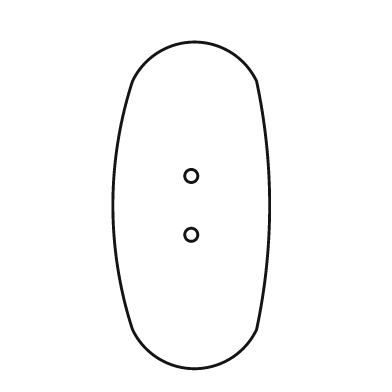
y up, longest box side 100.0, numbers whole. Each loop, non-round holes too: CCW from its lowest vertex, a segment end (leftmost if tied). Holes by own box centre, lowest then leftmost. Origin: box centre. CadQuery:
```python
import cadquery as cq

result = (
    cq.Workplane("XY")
    .moveTo(-18.0, -38.0)
    .threePointArc((1.0, -50.0), (20.0, -38.0))
    .threePointArc((24.0, 0.0), (20.0, 38.0))
    .threePointArc((1.0, 50.0), (-18.0, 38.0))
    .threePointArc((-24.0, 0.0), (-18.0, -38.0))
    .close()
    .moveTo(0.0, -9.0)
    .circle(2.0)
    .moveTo(0.0, 9.0)
    .circle(2.0)
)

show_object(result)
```